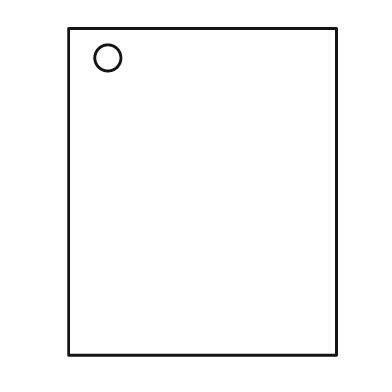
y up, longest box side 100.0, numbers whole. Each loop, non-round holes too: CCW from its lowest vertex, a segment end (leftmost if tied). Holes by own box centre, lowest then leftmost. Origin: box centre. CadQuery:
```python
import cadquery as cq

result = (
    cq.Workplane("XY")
    .moveTo(-41.0, -50.0)
    .lineTo(41.0, -50.0)
    .lineTo(41.0, 50.0)
    .lineTo(-41.0, 50.0)
    .close()
    .moveTo(-29.0, 41.0)
    .circle(4.0)
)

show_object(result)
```